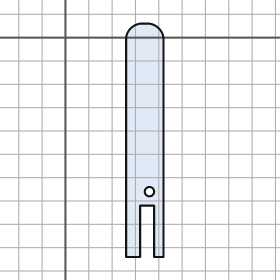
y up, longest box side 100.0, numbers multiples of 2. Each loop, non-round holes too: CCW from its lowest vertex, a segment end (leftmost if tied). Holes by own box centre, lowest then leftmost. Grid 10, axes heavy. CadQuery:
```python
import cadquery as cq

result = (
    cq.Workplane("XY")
    .moveTo(26.0, -94.0)
    .lineTo(32.0, -94.0)
    .lineTo(32.0, -72.0)
    .lineTo(38.0, -72.0)
    .lineTo(38.0, -94.0)
    .lineTo(42.0, -94.0)
    .lineTo(42.0, 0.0)
    .threePointArc((40.0, 4.0), (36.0, 6.0))
    .lineTo(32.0, 6.0)
    .threePointArc((28.0, 4.0), (26.0, 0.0))
    .close()
    .moveTo(36.0, -66.0)
    .circle(2.0)
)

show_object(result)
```